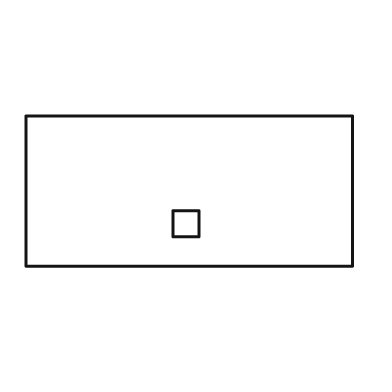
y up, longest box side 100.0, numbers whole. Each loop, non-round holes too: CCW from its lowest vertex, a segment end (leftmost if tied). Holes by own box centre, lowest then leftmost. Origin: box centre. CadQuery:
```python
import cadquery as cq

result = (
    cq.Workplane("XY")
    .moveTo(-50.0, -23.0)
    .lineTo(50.0, -23.0)
    .lineTo(50.0, 23.0)
    .lineTo(-50.0, 23.0)
    .close()
    .moveTo(-5.0, -14.0)
    .lineTo(3.0, -14.0)
    .lineTo(3.0, -6.0)
    .lineTo(-5.0, -6.0)
    .close()
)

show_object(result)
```